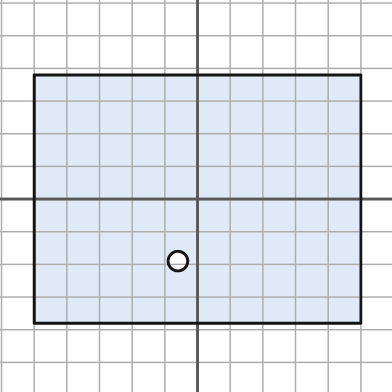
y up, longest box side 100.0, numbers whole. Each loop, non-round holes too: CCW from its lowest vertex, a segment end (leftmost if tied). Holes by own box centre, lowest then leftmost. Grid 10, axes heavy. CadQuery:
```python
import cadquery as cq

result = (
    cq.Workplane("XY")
    .moveTo(-50.0, -38.0)
    .lineTo(50.0, -38.0)
    .lineTo(50.0, 38.0)
    .lineTo(-50.0, 38.0)
    .close()
    .moveTo(-6.0, -19.0)
    .circle(3.0)
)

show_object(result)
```